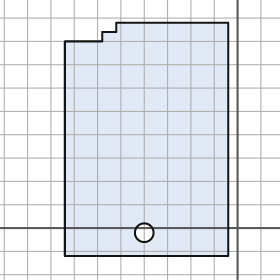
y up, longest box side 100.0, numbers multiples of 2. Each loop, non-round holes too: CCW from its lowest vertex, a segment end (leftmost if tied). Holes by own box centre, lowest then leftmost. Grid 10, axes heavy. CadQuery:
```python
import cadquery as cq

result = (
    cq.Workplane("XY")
    .moveTo(-74.0, -12.0)
    .lineTo(-4.0, -12.0)
    .lineTo(-4.0, 88.0)
    .lineTo(-52.0, 88.0)
    .lineTo(-52.0, 84.0)
    .lineTo(-58.0, 84.0)
    .lineTo(-58.0, 80.0)
    .lineTo(-74.0, 80.0)
    .close()
    .moveTo(-40.0, -2.0)
    .circle(4.0)
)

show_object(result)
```